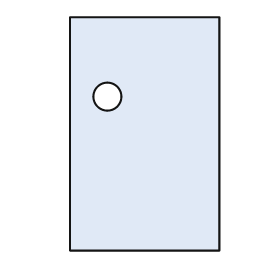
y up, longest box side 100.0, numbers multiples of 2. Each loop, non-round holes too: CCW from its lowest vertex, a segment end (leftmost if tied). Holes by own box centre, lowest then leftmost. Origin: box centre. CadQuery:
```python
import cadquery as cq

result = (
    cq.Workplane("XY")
    .moveTo(-32.0, -50.0)
    .lineTo(32.0, -50.0)
    .lineTo(32.0, 50.0)
    .lineTo(-32.0, 50.0)
    .close()
    .moveTo(-16.0, 16.0)
    .circle(6.0)
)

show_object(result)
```